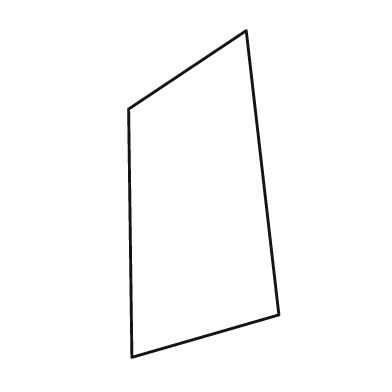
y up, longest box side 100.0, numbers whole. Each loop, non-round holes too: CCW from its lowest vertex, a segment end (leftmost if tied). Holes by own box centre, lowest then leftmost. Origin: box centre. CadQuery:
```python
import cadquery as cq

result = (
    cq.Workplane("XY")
    .moveTo(-22.0, -50.0)
    .lineTo(23.0, -37.0)
    .lineTo(13.0, 50.0)
    .lineTo(-23.0, 26.0)
    .close()
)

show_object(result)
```